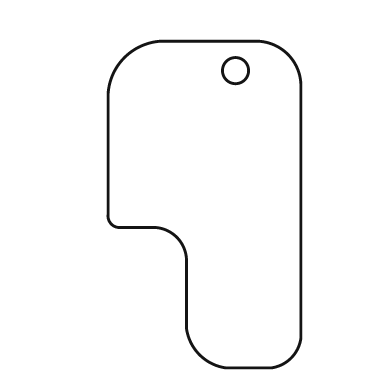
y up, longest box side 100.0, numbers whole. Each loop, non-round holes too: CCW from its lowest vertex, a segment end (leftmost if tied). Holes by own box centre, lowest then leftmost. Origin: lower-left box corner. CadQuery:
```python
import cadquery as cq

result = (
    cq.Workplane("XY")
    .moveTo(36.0, 0.0)
    .lineTo(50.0, 0.0)
    .threePointArc((56.0, 3.0), (59.0, 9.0))
    .lineTo(59.0, 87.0)
    .threePointArc((55.0, 96.0), (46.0, 100.0))
    .lineTo(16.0, 100.0)
    .threePointArc((5.0, 95.0), (0.0, 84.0))
    .lineTo(0.0, 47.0)
    .threePointArc((1.0, 44.0), (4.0, 43.0))
    .lineTo(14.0, 43.0)
    .threePointArc((21.0, 40.0), (24.0, 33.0))
    .lineTo(24.0, 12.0)
    .threePointArc((28.0, 4.0), (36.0, 0.0))
    .close()
    .moveTo(39.0, 91.0)
    .circle(4.0)
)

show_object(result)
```